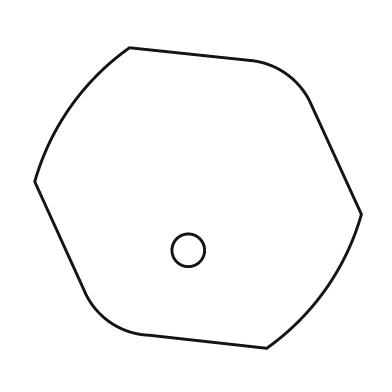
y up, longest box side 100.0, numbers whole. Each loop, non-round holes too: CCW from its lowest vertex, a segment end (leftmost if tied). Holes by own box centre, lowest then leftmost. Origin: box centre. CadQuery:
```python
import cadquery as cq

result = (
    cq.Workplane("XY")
    .moveTo(21.0, -46.0)
    .threePointArc((39.0, -28.0), (50.0, -5.0))
    .lineTo(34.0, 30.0)
    .threePointArc((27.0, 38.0), (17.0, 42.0))
    .lineTo(-21.0, 46.0)
    .threePointArc((-39.0, 28.0), (-50.0, 5.0))
    .lineTo(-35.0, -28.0)
    .threePointArc((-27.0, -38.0), (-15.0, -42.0))
    .close()
    .moveTo(-3.0, -16.0)
    .circle(5.0)
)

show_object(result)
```